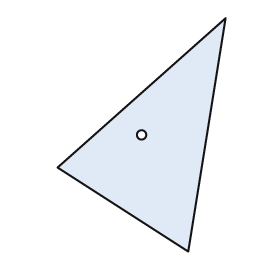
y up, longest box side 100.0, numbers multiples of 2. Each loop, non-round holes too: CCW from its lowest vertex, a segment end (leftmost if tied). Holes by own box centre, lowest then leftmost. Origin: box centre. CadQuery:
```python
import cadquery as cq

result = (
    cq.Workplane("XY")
    .moveTo(20.0, -50.0)
    .lineTo(36.0, 50.0)
    .lineTo(-36.0, -14.0)
    .close()
    .moveTo(0.0, 0.0)
    .circle(2.0)
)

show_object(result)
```